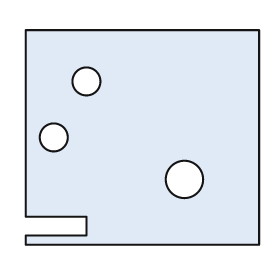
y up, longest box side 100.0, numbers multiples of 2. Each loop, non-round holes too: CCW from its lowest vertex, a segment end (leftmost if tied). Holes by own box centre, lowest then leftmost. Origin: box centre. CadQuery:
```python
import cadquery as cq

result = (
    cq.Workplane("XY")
    .moveTo(-50.0, -46.0)
    .lineTo(50.0, -46.0)
    .lineTo(50.0, 46.0)
    .lineTo(-50.0, 46.0)
    .lineTo(-50.0, -34.0)
    .lineTo(-24.0, -34.0)
    .lineTo(-24.0, -42.0)
    .lineTo(-50.0, -42.0)
    .close()
    .moveTo(18.0, -18.0)
    .circle(8.0)
    .moveTo(-38.0, 0.0)
    .circle(6.0)
    .moveTo(-24.0, 24.0)
    .circle(6.0)
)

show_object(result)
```